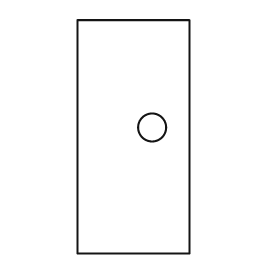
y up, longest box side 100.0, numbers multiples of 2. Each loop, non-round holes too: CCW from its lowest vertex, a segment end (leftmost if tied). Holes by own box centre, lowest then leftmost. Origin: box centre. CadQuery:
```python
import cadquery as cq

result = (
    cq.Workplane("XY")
    .moveTo(-24.0, -50.0)
    .lineTo(24.0, -50.0)
    .lineTo(24.0, 50.0)
    .lineTo(-24.0, 50.0)
    .close()
    .moveTo(8.0, 4.0)
    .circle(6.0)
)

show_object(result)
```